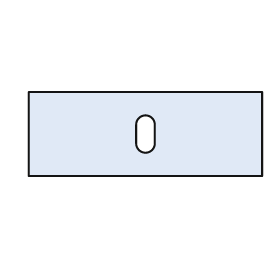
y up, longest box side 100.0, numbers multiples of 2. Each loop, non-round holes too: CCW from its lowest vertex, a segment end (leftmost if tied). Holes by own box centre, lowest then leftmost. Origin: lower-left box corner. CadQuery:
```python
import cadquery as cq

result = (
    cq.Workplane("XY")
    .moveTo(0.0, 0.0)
    .lineTo(100.0, 0.0)
    .lineTo(100.0, 36.0)
    .lineTo(0.0, 36.0)
    .close()
    .moveTo(46.0, 14.0)
    .threePointArc((50.0, 10.0), (54.0, 14.0))
    .lineTo(54.0, 22.0)
    .threePointArc((50.0, 26.0), (46.0, 22.0))
    .close()
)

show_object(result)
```